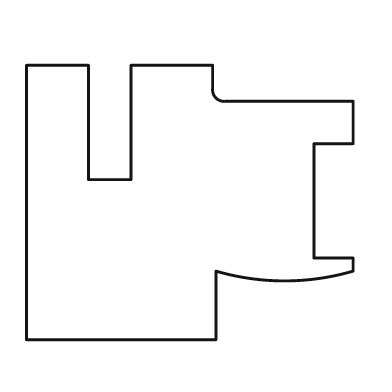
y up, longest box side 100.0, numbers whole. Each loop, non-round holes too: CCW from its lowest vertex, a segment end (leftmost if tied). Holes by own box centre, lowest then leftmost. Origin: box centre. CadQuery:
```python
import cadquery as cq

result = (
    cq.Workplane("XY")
    .moveTo(-50.0, -42.0)
    .lineTo(8.0, -42.0)
    .lineTo(8.0, -21.0)
    .threePointArc((29.0, -24.0), (50.0, -21.0))
    .lineTo(50.0, -17.0)
    .lineTo(38.0, -17.0)
    .lineTo(38.0, 18.0)
    .lineTo(50.0, 18.0)
    .lineTo(50.0, 31.0)
    .lineTo(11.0, 31.0)
    .threePointArc((8.0, 32.0), (7.0, 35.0))
    .lineTo(7.0, 42.0)
    .lineTo(-18.0, 42.0)
    .lineTo(-18.0, 7.0)
    .lineTo(-31.0, 7.0)
    .lineTo(-31.0, 42.0)
    .lineTo(-50.0, 42.0)
    .close()
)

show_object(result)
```